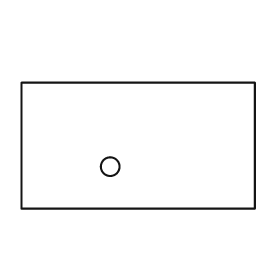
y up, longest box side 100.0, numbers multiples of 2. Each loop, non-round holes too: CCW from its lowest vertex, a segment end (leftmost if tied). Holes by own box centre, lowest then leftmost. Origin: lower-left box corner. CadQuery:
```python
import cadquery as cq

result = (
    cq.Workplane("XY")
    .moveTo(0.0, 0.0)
    .lineTo(100.0, 0.0)
    .lineTo(100.0, 54.0)
    .lineTo(0.0, 54.0)
    .close()
    .moveTo(38.0, 18.0)
    .circle(4.0)
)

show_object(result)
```